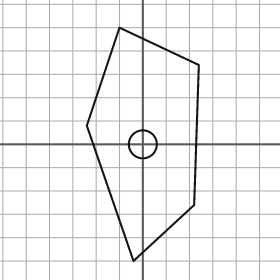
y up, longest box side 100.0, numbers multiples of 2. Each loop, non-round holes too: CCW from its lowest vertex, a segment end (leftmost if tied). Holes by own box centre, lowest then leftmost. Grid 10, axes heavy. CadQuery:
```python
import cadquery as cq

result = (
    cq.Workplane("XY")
    .moveTo(-4.0, -50.0)
    .lineTo(22.0, -26.0)
    .lineTo(24.0, 34.0)
    .lineTo(-10.0, 50.0)
    .lineTo(-24.0, 8.0)
    .close()
    .moveTo(0.0, 0.0)
    .circle(6.0)
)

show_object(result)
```